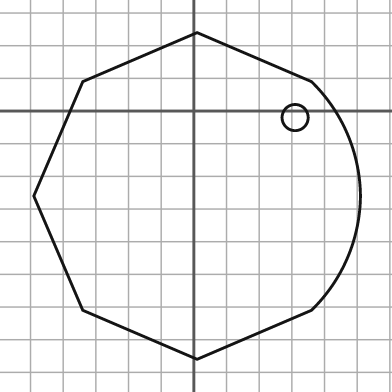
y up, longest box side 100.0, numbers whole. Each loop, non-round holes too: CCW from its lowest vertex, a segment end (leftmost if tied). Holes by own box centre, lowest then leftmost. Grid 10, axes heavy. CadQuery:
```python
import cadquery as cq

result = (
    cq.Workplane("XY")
    .moveTo(1.0, -76.0)
    .lineTo(36.0, -61.0)
    .threePointArc((47.0, -45.0), (51.0, -26.0))
    .threePointArc((47.0, -7.0), (36.0, 9.0))
    .lineTo(1.0, 24.0)
    .lineTo(-34.0, 9.0)
    .lineTo(-49.0, -26.0)
    .lineTo(-34.0, -61.0)
    .close()
    .moveTo(31.0, -2.0)
    .circle(4.0)
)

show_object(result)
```